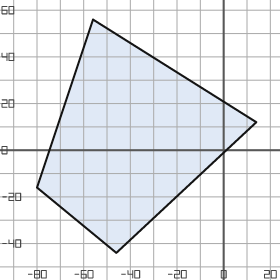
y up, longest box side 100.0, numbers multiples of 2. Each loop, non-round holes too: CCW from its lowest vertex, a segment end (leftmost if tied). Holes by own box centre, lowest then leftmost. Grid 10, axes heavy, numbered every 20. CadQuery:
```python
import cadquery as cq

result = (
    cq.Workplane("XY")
    .moveTo(-46.0, -44.0)
    .lineTo(14.0, 12.0)
    .lineTo(-56.0, 56.0)
    .lineTo(-80.0, -16.0)
    .close()
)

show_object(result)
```